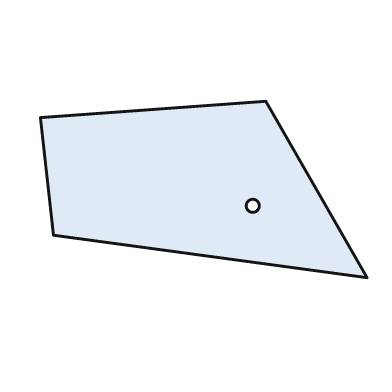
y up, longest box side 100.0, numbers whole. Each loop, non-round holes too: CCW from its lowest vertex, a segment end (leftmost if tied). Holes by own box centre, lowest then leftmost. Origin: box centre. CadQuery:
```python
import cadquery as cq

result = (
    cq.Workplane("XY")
    .moveTo(50.0, -27.0)
    .lineTo(19.0, 27.0)
    .lineTo(-50.0, 22.0)
    .lineTo(-46.0, -14.0)
    .close()
    .moveTo(15.0, -5.0)
    .circle(2.0)
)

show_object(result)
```